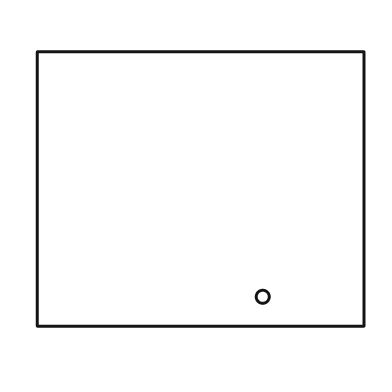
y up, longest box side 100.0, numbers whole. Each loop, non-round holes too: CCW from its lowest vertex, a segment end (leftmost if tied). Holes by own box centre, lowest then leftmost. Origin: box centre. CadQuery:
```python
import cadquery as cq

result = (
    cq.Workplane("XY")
    .moveTo(-50.0, -42.0)
    .lineTo(50.0, -42.0)
    .lineTo(50.0, 42.0)
    .lineTo(-50.0, 42.0)
    .close()
    .moveTo(19.0, -33.0)
    .circle(2.0)
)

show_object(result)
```